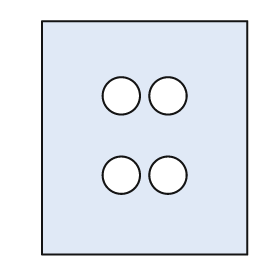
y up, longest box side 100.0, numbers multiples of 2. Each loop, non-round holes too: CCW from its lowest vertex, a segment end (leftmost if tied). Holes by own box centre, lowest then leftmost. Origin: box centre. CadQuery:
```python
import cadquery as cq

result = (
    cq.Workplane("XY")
    .moveTo(-44.0, -50.0)
    .lineTo(44.0, -50.0)
    .lineTo(44.0, 50.0)
    .lineTo(-44.0, 50.0)
    .close()
    .moveTo(-10.0, -16.0)
    .circle(8.0)
    .moveTo(10.0, -16.0)
    .circle(8.0)
    .moveTo(-10.0, 18.0)
    .circle(8.0)
    .moveTo(10.0, 18.0)
    .circle(8.0)
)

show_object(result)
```